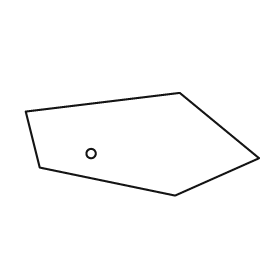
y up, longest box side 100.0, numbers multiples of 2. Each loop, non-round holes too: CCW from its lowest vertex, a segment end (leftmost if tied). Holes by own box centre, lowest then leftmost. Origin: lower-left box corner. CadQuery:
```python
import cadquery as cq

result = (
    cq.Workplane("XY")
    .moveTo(64.0, 0.0)
    .lineTo(100.0, 16.0)
    .lineTo(66.0, 44.0)
    .lineTo(0.0, 36.0)
    .lineTo(6.0, 12.0)
    .close()
    .moveTo(28.0, 18.0)
    .circle(2.0)
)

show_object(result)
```